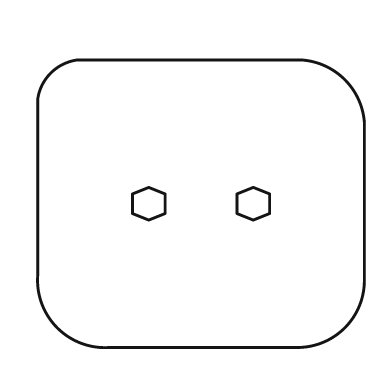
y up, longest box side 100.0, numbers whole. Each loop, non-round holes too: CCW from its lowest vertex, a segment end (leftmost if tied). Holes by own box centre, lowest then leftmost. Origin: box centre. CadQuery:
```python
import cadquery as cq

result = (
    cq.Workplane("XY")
    .moveTo(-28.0, -44.0)
    .lineTo(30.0, -44.0)
    .threePointArc((44.0, -38.0), (50.0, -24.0))
    .lineTo(50.0, 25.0)
    .threePointArc((44.0, 38.0), (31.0, 44.0))
    .lineTo(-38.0, 44.0)
    .threePointArc((-46.0, 40.0), (-50.0, 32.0))
    .lineTo(-50.0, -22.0)
    .threePointArc((-44.0, -38.0), (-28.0, -44.0))
    .close()
    .moveTo(-16.0, -5.0)
    .lineTo(-11.0, -3.0)
    .lineTo(-11.0, 3.0)
    .lineTo(-16.0, 5.0)
    .lineTo(-21.0, 3.0)
    .lineTo(-21.0, -3.0)
    .close()
    .moveTo(16.0, -5.0)
    .lineTo(21.0, -3.0)
    .lineTo(21.0, 3.0)
    .lineTo(16.0, 5.0)
    .lineTo(11.0, 3.0)
    .lineTo(11.0, -3.0)
    .close()
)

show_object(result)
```